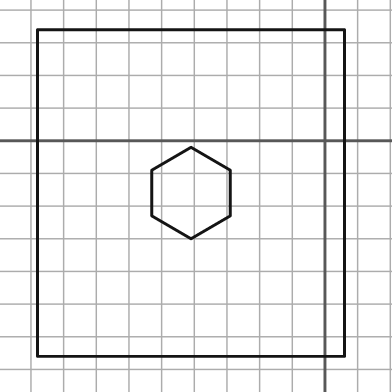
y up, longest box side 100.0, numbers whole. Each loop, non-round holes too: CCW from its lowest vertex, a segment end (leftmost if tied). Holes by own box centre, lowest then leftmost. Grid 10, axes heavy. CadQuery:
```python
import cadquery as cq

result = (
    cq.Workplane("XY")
    .moveTo(-88.0, -66.0)
    .lineTo(6.0, -66.0)
    .lineTo(6.0, 34.0)
    .lineTo(-88.0, 34.0)
    .close()
    .moveTo(-41.0, -30.0)
    .lineTo(-29.0, -23.0)
    .lineTo(-29.0, -9.0)
    .lineTo(-41.0, -2.0)
    .lineTo(-53.0, -9.0)
    .lineTo(-53.0, -23.0)
    .close()
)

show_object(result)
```